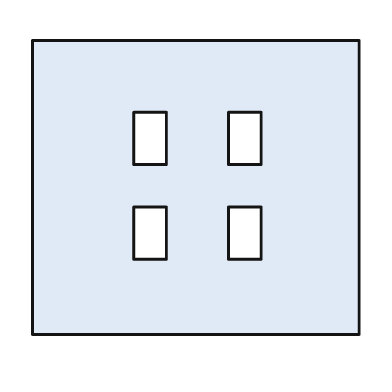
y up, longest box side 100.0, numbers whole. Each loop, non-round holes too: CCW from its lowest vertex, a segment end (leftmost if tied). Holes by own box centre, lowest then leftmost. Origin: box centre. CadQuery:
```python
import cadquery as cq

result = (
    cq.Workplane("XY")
    .moveTo(-50.0, -45.0)
    .lineTo(50.0, -45.0)
    .lineTo(50.0, 45.0)
    .lineTo(-50.0, 45.0)
    .close()
    .moveTo(-19.0, -22.0)
    .lineTo(-9.0, -22.0)
    .lineTo(-9.0, -6.0)
    .lineTo(-19.0, -6.0)
    .close()
    .moveTo(10.0, -22.0)
    .lineTo(20.0, -22.0)
    .lineTo(20.0, -6.0)
    .lineTo(10.0, -6.0)
    .close()
    .moveTo(-19.0, 7.0)
    .lineTo(-9.0, 7.0)
    .lineTo(-9.0, 23.0)
    .lineTo(-19.0, 23.0)
    .close()
    .moveTo(10.0, 7.0)
    .lineTo(20.0, 7.0)
    .lineTo(20.0, 23.0)
    .lineTo(10.0, 23.0)
    .close()
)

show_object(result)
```